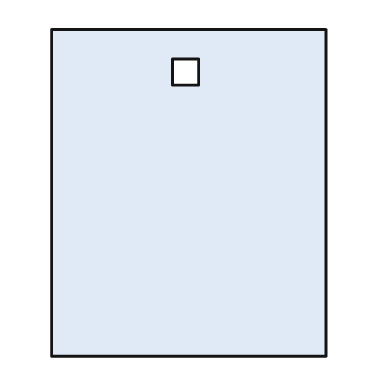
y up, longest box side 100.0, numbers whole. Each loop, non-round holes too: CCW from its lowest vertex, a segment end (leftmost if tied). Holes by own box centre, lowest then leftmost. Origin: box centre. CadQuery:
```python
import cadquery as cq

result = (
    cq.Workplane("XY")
    .moveTo(-42.0, -50.0)
    .lineTo(42.0, -50.0)
    .lineTo(42.0, 50.0)
    .lineTo(-42.0, 50.0)
    .close()
    .moveTo(-5.0, 33.0)
    .lineTo(3.0, 33.0)
    .lineTo(3.0, 41.0)
    .lineTo(-5.0, 41.0)
    .close()
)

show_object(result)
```